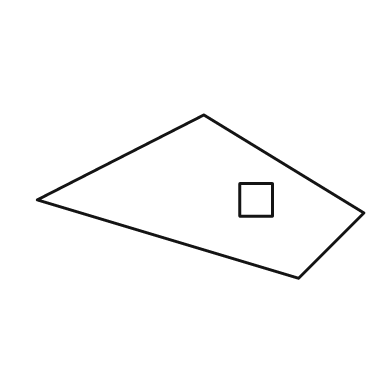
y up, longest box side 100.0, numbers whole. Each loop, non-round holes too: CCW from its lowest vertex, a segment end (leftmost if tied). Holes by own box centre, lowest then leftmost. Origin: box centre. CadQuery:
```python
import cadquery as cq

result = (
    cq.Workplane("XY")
    .moveTo(30.0, -25.0)
    .lineTo(50.0, -5.0)
    .lineTo(1.0, 25.0)
    .lineTo(-50.0, -1.0)
    .close()
    .moveTo(12.0, -6.0)
    .lineTo(22.0, -6.0)
    .lineTo(22.0, 4.0)
    .lineTo(12.0, 4.0)
    .close()
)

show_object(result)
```